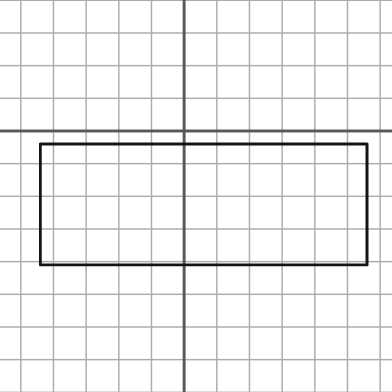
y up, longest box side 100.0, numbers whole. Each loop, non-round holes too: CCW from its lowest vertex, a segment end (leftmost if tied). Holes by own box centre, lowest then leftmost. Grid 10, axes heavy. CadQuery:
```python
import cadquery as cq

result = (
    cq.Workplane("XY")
    .moveTo(-44.0, -41.0)
    .lineTo(56.0, -41.0)
    .lineTo(56.0, -4.0)
    .lineTo(-44.0, -4.0)
    .close()
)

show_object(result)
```